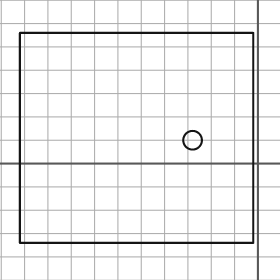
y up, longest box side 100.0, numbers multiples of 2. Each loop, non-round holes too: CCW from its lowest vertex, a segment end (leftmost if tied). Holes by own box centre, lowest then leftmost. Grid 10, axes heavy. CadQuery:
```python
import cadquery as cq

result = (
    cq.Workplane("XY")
    .moveTo(-102.0, -34.0)
    .lineTo(-2.0, -34.0)
    .lineTo(-2.0, 56.0)
    .lineTo(-102.0, 56.0)
    .close()
    .moveTo(-28.0, 10.0)
    .circle(4.0)
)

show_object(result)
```